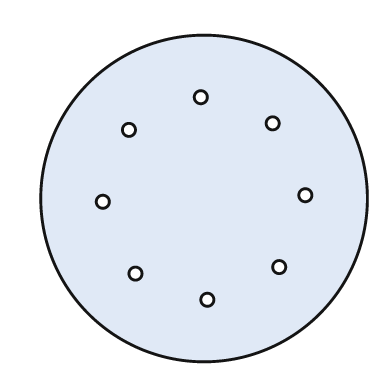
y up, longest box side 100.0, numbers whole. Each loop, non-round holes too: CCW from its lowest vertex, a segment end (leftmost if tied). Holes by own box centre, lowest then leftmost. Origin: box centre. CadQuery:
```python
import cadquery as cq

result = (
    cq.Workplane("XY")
    .moveTo(0.0, 0.0)
    .circle(50.0)
    .moveTo(1.0, -31.0)
    .circle(2.0)
    .moveTo(-21.0, -23.0)
    .circle(2.0)
    .moveTo(23.0, -21.0)
    .circle(2.0)
    .moveTo(-31.0, -1.0)
    .circle(2.0)
    .moveTo(31.0, 1.0)
    .circle(2.0)
    .moveTo(-23.0, 21.0)
    .circle(2.0)
    .moveTo(21.0, 23.0)
    .circle(2.0)
    .moveTo(-1.0, 31.0)
    .circle(2.0)
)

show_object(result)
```